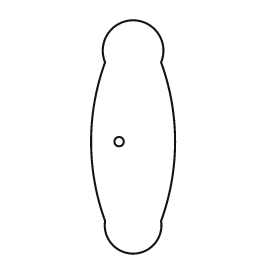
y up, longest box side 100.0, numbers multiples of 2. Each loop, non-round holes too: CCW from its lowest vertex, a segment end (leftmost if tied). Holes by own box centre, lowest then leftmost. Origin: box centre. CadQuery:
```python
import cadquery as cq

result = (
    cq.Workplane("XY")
    .moveTo(-12.0, -36.0)
    .threePointArc((0.0, -50.0), (12.0, -36.0))
    .threePointArc((18.0, -2.0), (12.0, 32.0))
    .threePointArc((0.0, 50.0), (-12.0, 32.0))
    .threePointArc((-18.0, -2.0), (-12.0, -36.0))
    .close()
    .moveTo(-6.0, -2.0)
    .circle(2.0)
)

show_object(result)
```